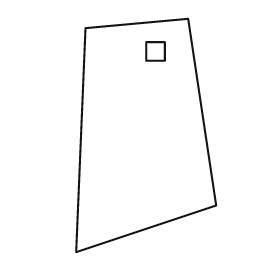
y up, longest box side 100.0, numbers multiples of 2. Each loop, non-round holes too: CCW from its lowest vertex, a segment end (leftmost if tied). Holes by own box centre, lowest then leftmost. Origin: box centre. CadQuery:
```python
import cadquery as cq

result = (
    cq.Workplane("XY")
    .moveTo(-30.0, -50.0)
    .lineTo(30.0, -30.0)
    .lineTo(18.0, 50.0)
    .lineTo(-26.0, 46.0)
    .close()
    .moveTo(0.0, 32.0)
    .lineTo(8.0, 32.0)
    .lineTo(8.0, 40.0)
    .lineTo(0.0, 40.0)
    .close()
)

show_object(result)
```